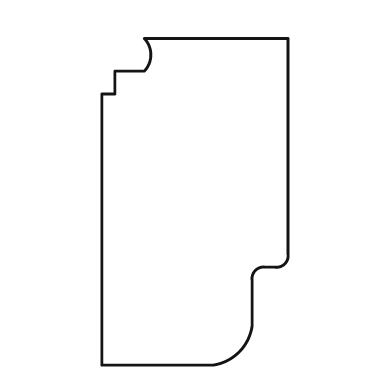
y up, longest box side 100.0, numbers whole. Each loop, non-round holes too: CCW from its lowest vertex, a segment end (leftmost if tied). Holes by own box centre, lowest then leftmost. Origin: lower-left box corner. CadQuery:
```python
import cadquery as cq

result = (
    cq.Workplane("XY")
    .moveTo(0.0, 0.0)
    .lineTo(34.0, 0.0)
    .threePointArc((42.0, 4.0), (46.0, 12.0))
    .lineTo(46.0, 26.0)
    .threePointArc((47.0, 29.0), (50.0, 30.0))
    .lineTo(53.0, 30.0)
    .threePointArc((56.0, 31.0), (57.0, 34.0))
    .lineTo(57.0, 100.0)
    .lineTo(13.0, 100.0)
    .threePointArc((15.0, 95.0), (13.0, 90.0))
    .lineTo(4.0, 90.0)
    .lineTo(4.0, 83.0)
    .lineTo(0.0, 83.0)
    .close()
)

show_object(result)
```